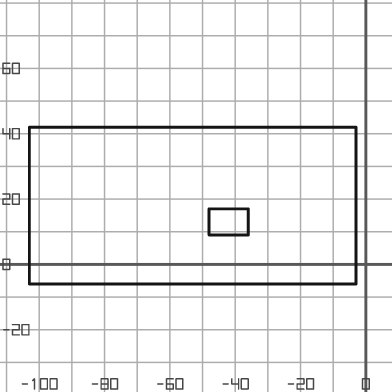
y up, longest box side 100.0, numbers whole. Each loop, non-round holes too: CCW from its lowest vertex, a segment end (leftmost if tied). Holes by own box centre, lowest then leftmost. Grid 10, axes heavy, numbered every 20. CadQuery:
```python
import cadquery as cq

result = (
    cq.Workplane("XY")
    .moveTo(-103.0, -6.0)
    .lineTo(-3.0, -6.0)
    .lineTo(-3.0, 42.0)
    .lineTo(-103.0, 42.0)
    .close()
    .moveTo(-48.0, 9.0)
    .lineTo(-36.0, 9.0)
    .lineTo(-36.0, 17.0)
    .lineTo(-48.0, 17.0)
    .close()
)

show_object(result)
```